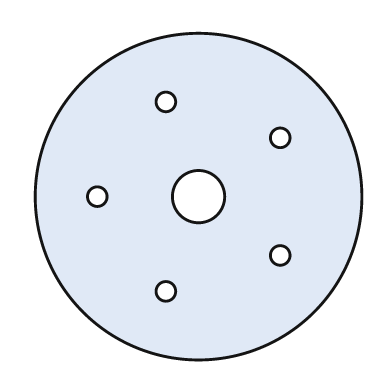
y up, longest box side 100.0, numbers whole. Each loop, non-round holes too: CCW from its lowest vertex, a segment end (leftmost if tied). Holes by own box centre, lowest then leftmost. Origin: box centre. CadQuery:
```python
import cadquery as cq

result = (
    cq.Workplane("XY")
    .moveTo(0.0, 0.0)
    .circle(50.0)
    .moveTo(-10.0, -29.0)
    .circle(3.0)
    .moveTo(25.0, -18.0)
    .circle(3.0)
    .moveTo(-31.0, 0.0)
    .circle(3.0)
    .moveTo(0.0, 0.0)
    .circle(8.0)
    .moveTo(25.0, 18.0)
    .circle(3.0)
    .moveTo(-10.0, 29.0)
    .circle(3.0)
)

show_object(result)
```